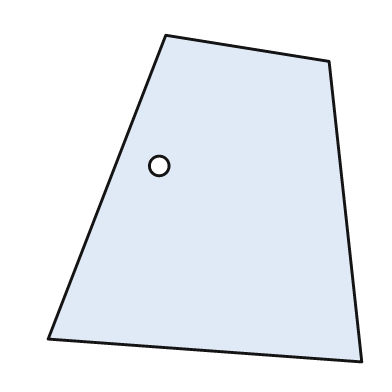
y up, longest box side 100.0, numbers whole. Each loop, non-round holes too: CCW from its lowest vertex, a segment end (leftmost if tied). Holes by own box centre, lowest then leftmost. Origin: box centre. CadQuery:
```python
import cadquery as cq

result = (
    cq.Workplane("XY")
    .moveTo(48.0, -50.0)
    .lineTo(38.0, 42.0)
    .lineTo(-12.0, 50.0)
    .lineTo(-48.0, -43.0)
    .close()
    .moveTo(-14.0, 10.0)
    .circle(3.0)
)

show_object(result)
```